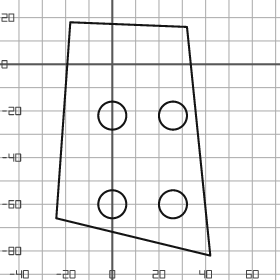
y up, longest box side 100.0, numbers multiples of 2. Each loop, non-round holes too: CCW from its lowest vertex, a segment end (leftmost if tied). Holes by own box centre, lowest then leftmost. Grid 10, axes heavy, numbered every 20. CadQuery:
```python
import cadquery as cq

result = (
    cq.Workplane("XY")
    .moveTo(42.0, -82.0)
    .lineTo(32.0, 16.0)
    .lineTo(-18.0, 18.0)
    .lineTo(-24.0, -66.0)
    .close()
    .moveTo(0.0, -60.0)
    .circle(6.0)
    .moveTo(26.0, -60.0)
    .circle(6.0)
    .moveTo(0.0, -22.0)
    .circle(6.0)
    .moveTo(26.0, -22.0)
    .circle(6.0)
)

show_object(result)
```